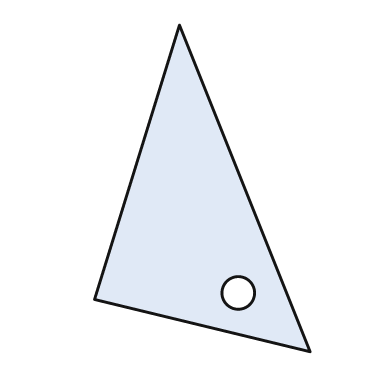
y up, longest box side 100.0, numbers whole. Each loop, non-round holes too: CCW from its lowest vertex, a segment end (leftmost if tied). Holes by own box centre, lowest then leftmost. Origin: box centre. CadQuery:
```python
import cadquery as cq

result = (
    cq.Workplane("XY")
    .moveTo(33.0, -50.0)
    .lineTo(-7.0, 50.0)
    .lineTo(-33.0, -34.0)
    .close()
    .moveTo(11.0, -32.0)
    .circle(5.0)
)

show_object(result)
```